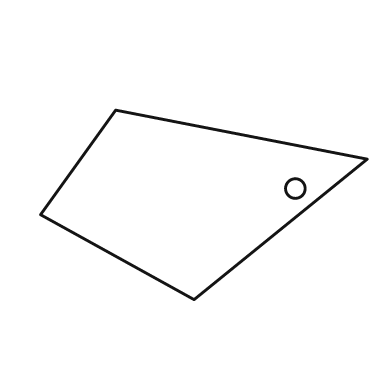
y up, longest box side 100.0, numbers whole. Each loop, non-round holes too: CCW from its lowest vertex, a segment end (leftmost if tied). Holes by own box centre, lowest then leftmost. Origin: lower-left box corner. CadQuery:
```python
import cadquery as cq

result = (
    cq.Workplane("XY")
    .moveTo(47.0, 0.0)
    .lineTo(100.0, 43.0)
    .lineTo(23.0, 58.0)
    .lineTo(0.0, 26.0)
    .close()
    .moveTo(78.0, 34.0)
    .circle(3.0)
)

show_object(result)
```